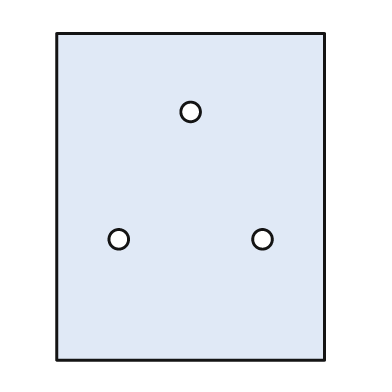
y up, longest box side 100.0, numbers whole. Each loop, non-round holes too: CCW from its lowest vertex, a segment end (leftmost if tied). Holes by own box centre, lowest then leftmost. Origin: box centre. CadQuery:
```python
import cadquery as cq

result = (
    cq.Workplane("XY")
    .moveTo(-41.0, -50.0)
    .lineTo(41.0, -50.0)
    .lineTo(41.0, 50.0)
    .lineTo(-41.0, 50.0)
    .close()
    .moveTo(-22.0, -13.0)
    .circle(3.0)
    .moveTo(22.0, -13.0)
    .circle(3.0)
    .moveTo(0.0, 26.0)
    .circle(3.0)
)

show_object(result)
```